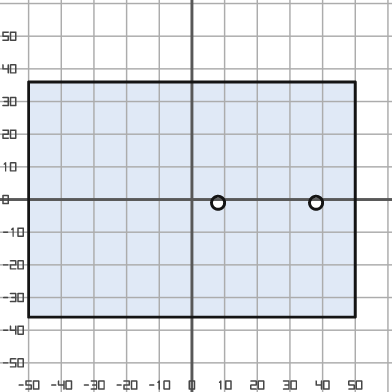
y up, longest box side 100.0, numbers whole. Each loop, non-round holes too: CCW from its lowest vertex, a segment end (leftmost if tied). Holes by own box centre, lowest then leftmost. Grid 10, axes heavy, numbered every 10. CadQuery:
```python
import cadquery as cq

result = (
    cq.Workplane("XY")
    .moveTo(-50.0, -36.0)
    .lineTo(50.0, -36.0)
    .lineTo(50.0, 36.0)
    .lineTo(-50.0, 36.0)
    .close()
    .moveTo(8.0, -1.0)
    .circle(2.0)
    .moveTo(38.0, -1.0)
    .circle(2.0)
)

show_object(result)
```